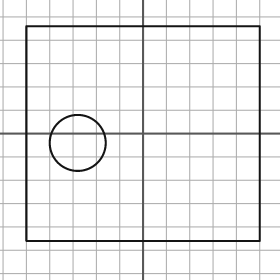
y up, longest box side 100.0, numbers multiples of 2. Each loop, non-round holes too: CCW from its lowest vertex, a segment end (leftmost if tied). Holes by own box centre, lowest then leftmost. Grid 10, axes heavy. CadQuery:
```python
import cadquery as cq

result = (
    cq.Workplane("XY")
    .moveTo(-50.0, -46.0)
    .lineTo(50.0, -46.0)
    .lineTo(50.0, 46.0)
    .lineTo(-50.0, 46.0)
    .close()
    .moveTo(-28.0, -4.0)
    .circle(12.0)
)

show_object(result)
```